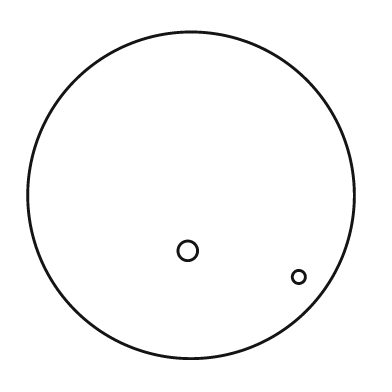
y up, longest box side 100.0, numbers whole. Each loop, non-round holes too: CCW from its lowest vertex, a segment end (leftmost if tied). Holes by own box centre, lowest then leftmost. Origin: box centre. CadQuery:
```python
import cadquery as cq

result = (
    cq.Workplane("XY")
    .moveTo(0.0, 0.0)
    .circle(50.0)
    .moveTo(33.0, -25.0)
    .circle(2.0)
    .moveTo(-1.0, -17.0)
    .circle(3.0)
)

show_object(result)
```